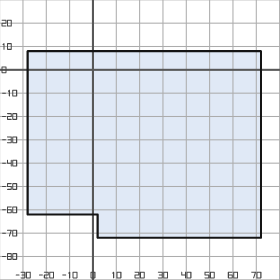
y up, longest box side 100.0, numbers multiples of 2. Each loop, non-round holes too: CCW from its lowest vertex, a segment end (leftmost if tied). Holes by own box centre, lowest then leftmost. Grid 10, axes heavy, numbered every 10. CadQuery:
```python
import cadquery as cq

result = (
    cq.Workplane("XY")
    .moveTo(2.0, -72.0)
    .lineTo(72.0, -72.0)
    .lineTo(72.0, 8.0)
    .lineTo(-28.0, 8.0)
    .lineTo(-28.0, -62.0)
    .lineTo(2.0, -62.0)
    .close()
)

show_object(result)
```